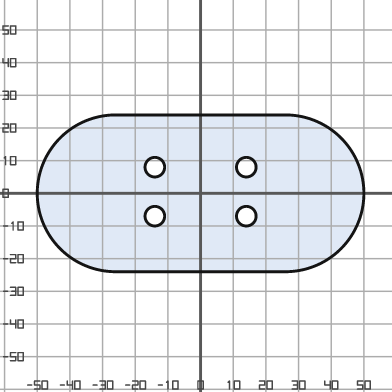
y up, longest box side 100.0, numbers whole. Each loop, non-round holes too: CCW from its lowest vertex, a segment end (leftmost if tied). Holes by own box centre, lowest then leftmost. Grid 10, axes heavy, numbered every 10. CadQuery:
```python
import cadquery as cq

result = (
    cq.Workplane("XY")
    .moveTo(-26.0, -24.0)
    .lineTo(26.0, -24.0)
    .threePointArc((50.0, 0.0), (26.0, 24.0))
    .lineTo(-26.0, 24.0)
    .threePointArc((-50.0, 0.0), (-26.0, -24.0))
    .close()
    .moveTo(-14.0, -7.0)
    .circle(3.0)
    .moveTo(14.0, -7.0)
    .circle(3.0)
    .moveTo(-14.0, 8.0)
    .circle(3.0)
    .moveTo(14.0, 8.0)
    .circle(3.0)
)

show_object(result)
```